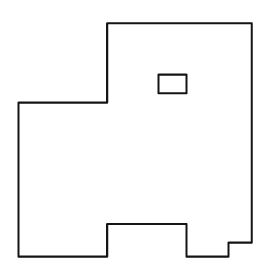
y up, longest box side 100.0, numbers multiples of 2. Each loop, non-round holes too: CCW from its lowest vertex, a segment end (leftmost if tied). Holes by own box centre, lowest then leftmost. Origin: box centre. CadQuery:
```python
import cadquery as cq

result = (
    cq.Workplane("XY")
    .moveTo(-50.0, -50.0)
    .lineTo(-12.0, -50.0)
    .lineTo(-12.0, -36.0)
    .lineTo(22.0, -36.0)
    .lineTo(22.0, -50.0)
    .lineTo(40.0, -50.0)
    .lineTo(40.0, -44.0)
    .lineTo(50.0, -44.0)
    .lineTo(50.0, 50.0)
    .lineTo(-12.0, 50.0)
    .lineTo(-12.0, 16.0)
    .lineTo(-50.0, 16.0)
    .close()
    .moveTo(10.0, 20.0)
    .lineTo(22.0, 20.0)
    .lineTo(22.0, 28.0)
    .lineTo(10.0, 28.0)
    .close()
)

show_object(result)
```